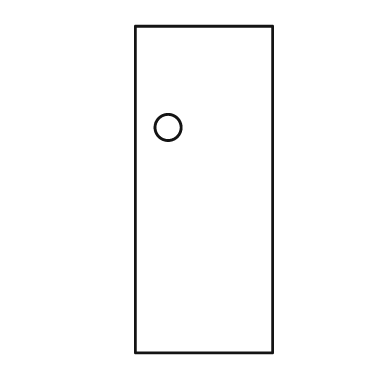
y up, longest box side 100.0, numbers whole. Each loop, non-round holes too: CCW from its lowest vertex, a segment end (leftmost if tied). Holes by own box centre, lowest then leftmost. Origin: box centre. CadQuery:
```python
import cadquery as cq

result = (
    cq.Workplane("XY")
    .moveTo(-21.0, -50.0)
    .lineTo(21.0, -50.0)
    .lineTo(21.0, 50.0)
    .lineTo(-21.0, 50.0)
    .close()
    .moveTo(-11.0, 19.0)
    .circle(4.0)
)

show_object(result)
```